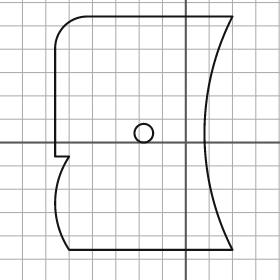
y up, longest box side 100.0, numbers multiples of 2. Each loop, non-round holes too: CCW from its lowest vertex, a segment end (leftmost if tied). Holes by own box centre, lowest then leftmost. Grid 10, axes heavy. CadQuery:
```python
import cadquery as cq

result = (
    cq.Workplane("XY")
    .moveTo(-50.0, -46.0)
    .lineTo(20.0, -46.0)
    .threePointArc((8.0, 4.0), (20.0, 54.0))
    .lineTo(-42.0, 54.0)
    .threePointArc((-52.0, 50.0), (-56.0, 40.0))
    .lineTo(-56.0, -6.0)
    .lineTo(-50.0, -6.0)
    .threePointArc((-56.0, -26.0), (-50.0, -46.0))
    .close()
    .moveTo(-18.0, 4.0)
    .circle(4.0)
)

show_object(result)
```